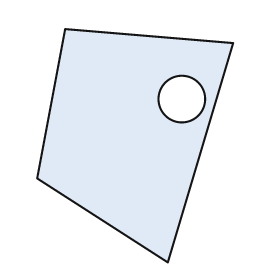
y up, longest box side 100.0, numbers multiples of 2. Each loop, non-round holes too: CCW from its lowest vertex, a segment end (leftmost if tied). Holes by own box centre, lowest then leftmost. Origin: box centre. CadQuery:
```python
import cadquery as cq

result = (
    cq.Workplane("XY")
    .moveTo(14.0, -50.0)
    .lineTo(42.0, 44.0)
    .lineTo(-30.0, 50.0)
    .lineTo(-42.0, -14.0)
    .close()
    .moveTo(20.0, 20.0)
    .circle(10.0)
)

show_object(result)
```